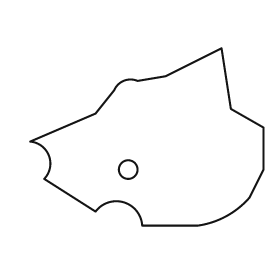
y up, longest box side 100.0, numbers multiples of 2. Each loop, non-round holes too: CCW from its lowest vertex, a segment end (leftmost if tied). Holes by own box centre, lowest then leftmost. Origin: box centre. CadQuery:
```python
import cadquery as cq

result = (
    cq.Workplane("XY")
    .moveTo(-2.0, -38.0)
    .lineTo(22.0, -38.0)
    .threePointArc((34.0, -34.0), (44.0, -26.0))
    .lineTo(50.0, -14.0)
    .lineTo(50.0, 4.0)
    .lineTo(36.0, 12.0)
    .lineTo(32.0, 38.0)
    .lineTo(8.0, 26.0)
    .lineTo(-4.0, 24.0)
    .threePointArc((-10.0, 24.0), (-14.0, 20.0))
    .lineTo(-22.0, 10.0)
    .lineTo(-50.0, -2.0)
    .threePointArc((-42.0, -8.0), (-44.0, -18.0))
    .lineTo(-22.0, -32.0)
    .threePointArc((-10.0, -28.0), (-2.0, -38.0))
    .close()
    .moveTo(-8.0, -14.0)
    .circle(4.0)
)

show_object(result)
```